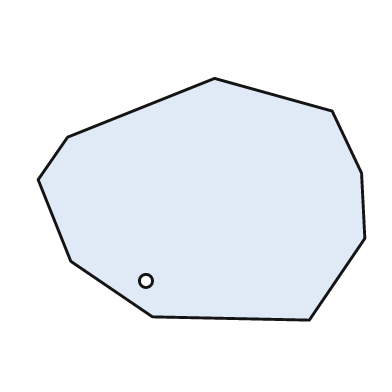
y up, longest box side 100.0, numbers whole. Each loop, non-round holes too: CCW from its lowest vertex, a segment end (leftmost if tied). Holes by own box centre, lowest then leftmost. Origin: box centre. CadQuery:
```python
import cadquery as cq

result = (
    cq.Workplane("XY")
    .moveTo(33.0, -37.0)
    .lineTo(50.0, -12.0)
    .lineTo(49.0, 8.0)
    .lineTo(40.0, 27.0)
    .lineTo(4.0, 37.0)
    .lineTo(-41.0, 19.0)
    .lineTo(-50.0, 6.0)
    .lineTo(-40.0, -19.0)
    .lineTo(-15.0, -36.0)
    .close()
    .moveTo(-17.0, -25.0)
    .circle(2.0)
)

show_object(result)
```